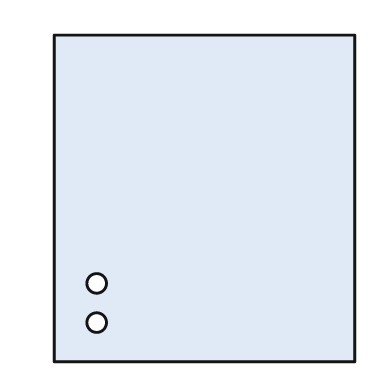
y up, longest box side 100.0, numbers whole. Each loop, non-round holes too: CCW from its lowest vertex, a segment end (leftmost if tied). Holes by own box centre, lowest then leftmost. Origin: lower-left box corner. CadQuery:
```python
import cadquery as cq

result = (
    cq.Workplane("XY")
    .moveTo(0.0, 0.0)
    .lineTo(92.0, 0.0)
    .lineTo(92.0, 100.0)
    .lineTo(0.0, 100.0)
    .close()
    .moveTo(13.0, 12.0)
    .circle(3.0)
    .moveTo(13.0, 24.0)
    .circle(3.0)
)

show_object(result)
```